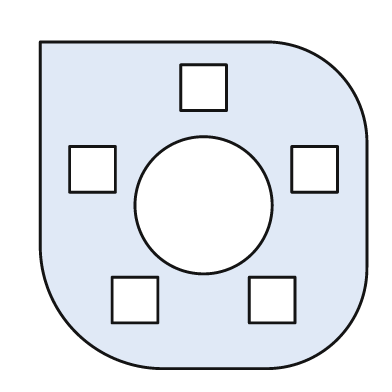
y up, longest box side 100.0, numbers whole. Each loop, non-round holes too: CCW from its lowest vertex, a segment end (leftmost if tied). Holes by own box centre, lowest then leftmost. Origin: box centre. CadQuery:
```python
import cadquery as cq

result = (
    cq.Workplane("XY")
    .moveTo(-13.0, -50.0)
    .lineTo(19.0, -50.0)
    .threePointArc((41.0, -41.0), (50.0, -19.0))
    .lineTo(50.0, 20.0)
    .threePointArc((41.0, 41.0), (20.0, 50.0))
    .lineTo(-50.0, 50.0)
    .lineTo(-50.0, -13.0)
    .threePointArc((-39.0, -39.0), (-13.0, -50.0))
    .close()
    .moveTo(-28.0, -36.0)
    .lineTo(-14.0, -36.0)
    .lineTo(-14.0, -22.0)
    .lineTo(-28.0, -22.0)
    .close()
    .moveTo(14.0, -36.0)
    .lineTo(28.0, -36.0)
    .lineTo(28.0, -22.0)
    .lineTo(14.0, -22.0)
    .close()
    .moveTo(0.0, 0.0)
    .circle(21.0)
    .moveTo(-41.0, 4.0)
    .lineTo(-27.0, 4.0)
    .lineTo(-27.0, 18.0)
    .lineTo(-41.0, 18.0)
    .close()
    .moveTo(27.0, 4.0)
    .lineTo(41.0, 4.0)
    .lineTo(41.0, 18.0)
    .lineTo(27.0, 18.0)
    .close()
    .moveTo(-7.0, 29.0)
    .lineTo(7.0, 29.0)
    .lineTo(7.0, 43.0)
    .lineTo(-7.0, 43.0)
    .close()
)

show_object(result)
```